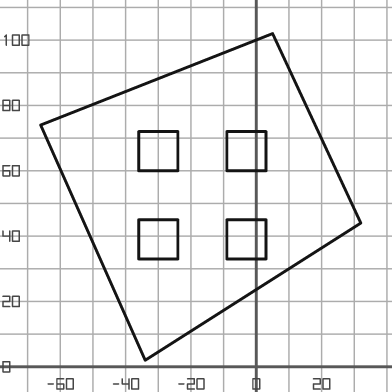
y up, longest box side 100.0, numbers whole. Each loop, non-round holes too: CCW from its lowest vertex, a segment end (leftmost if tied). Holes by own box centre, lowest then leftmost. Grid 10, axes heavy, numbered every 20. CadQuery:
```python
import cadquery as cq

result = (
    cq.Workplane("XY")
    .moveTo(-34.0, 2.0)
    .lineTo(32.0, 44.0)
    .lineTo(5.0, 102.0)
    .lineTo(-66.0, 74.0)
    .close()
    .moveTo(-36.0, 33.0)
    .lineTo(-24.0, 33.0)
    .lineTo(-24.0, 45.0)
    .lineTo(-36.0, 45.0)
    .close()
    .moveTo(-9.0, 33.0)
    .lineTo(3.0, 33.0)
    .lineTo(3.0, 45.0)
    .lineTo(-9.0, 45.0)
    .close()
    .moveTo(-36.0, 60.0)
    .lineTo(-24.0, 60.0)
    .lineTo(-24.0, 72.0)
    .lineTo(-36.0, 72.0)
    .close()
    .moveTo(-9.0, 60.0)
    .lineTo(3.0, 60.0)
    .lineTo(3.0, 72.0)
    .lineTo(-9.0, 72.0)
    .close()
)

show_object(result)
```